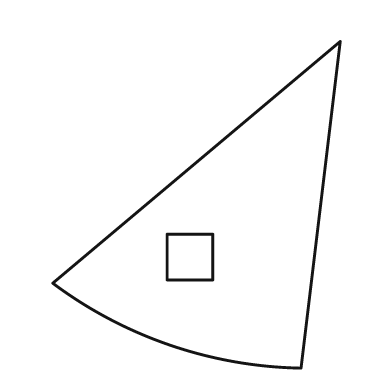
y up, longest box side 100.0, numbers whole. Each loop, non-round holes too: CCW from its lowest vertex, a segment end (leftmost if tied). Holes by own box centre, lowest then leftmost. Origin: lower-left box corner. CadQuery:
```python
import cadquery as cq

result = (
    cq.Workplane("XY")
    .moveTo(76.0, 0.0)
    .lineTo(88.0, 100.0)
    .lineTo(0.0, 26.0)
    .threePointArc((36.0, 7.0), (76.0, 0.0))
    .close()
    .moveTo(35.0, 27.0)
    .lineTo(49.0, 27.0)
    .lineTo(49.0, 41.0)
    .lineTo(35.0, 41.0)
    .close()
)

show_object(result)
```